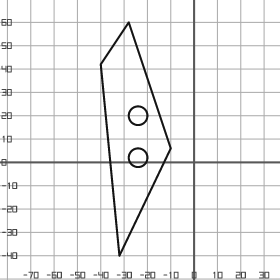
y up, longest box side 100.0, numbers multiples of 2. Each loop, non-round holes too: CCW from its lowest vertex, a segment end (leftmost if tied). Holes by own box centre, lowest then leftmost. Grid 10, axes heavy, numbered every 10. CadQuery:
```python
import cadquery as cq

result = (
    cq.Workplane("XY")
    .moveTo(-32.0, -40.0)
    .lineTo(-10.0, 6.0)
    .lineTo(-28.0, 60.0)
    .lineTo(-40.0, 42.0)
    .close()
    .moveTo(-24.0, 2.0)
    .circle(4.0)
    .moveTo(-24.0, 20.0)
    .circle(4.0)
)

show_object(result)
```